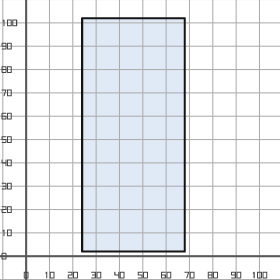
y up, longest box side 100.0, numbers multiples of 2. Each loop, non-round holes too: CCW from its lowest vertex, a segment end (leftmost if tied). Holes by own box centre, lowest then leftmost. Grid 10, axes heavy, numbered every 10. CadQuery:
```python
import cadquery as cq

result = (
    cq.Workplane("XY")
    .moveTo(24.0, 2.0)
    .lineTo(68.0, 2.0)
    .lineTo(68.0, 102.0)
    .lineTo(24.0, 102.0)
    .close()
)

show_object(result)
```